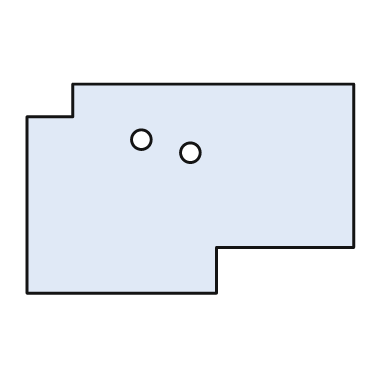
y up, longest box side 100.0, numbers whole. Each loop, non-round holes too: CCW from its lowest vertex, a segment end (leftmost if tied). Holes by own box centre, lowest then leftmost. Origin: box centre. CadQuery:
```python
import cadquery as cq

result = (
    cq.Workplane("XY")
    .moveTo(-50.0, -32.0)
    .lineTo(8.0, -32.0)
    .lineTo(8.0, -18.0)
    .lineTo(50.0, -18.0)
    .lineTo(50.0, 32.0)
    .lineTo(-36.0, 32.0)
    .lineTo(-36.0, 22.0)
    .lineTo(-50.0, 22.0)
    .close()
    .moveTo(0.0, 11.0)
    .circle(3.0)
    .moveTo(-15.0, 15.0)
    .circle(3.0)
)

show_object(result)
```